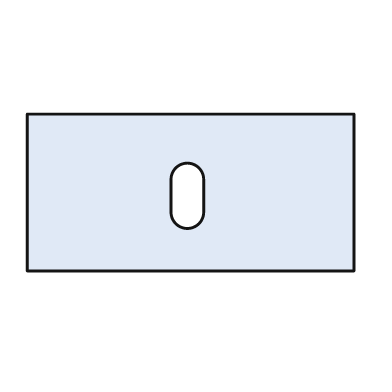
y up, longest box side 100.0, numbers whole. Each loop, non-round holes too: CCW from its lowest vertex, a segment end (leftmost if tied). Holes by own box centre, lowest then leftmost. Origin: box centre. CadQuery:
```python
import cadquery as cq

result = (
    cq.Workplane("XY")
    .moveTo(-50.0, -24.0)
    .lineTo(50.0, -24.0)
    .lineTo(50.0, 24.0)
    .lineTo(-50.0, 24.0)
    .close()
    .moveTo(-6.0, -6.0)
    .threePointArc((-1.0, -11.0), (4.0, -6.0))
    .lineTo(4.0, 4.0)
    .threePointArc((-1.0, 9.0), (-6.0, 4.0))
    .close()
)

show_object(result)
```